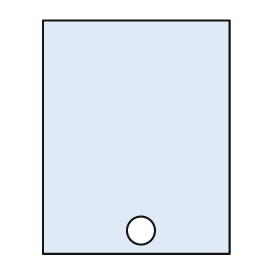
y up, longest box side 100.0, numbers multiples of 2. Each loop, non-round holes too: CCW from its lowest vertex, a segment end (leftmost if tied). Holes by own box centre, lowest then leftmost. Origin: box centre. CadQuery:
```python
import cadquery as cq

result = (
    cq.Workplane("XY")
    .moveTo(-40.0, -50.0)
    .lineTo(40.0, -50.0)
    .lineTo(40.0, 50.0)
    .lineTo(-40.0, 50.0)
    .close()
    .moveTo(2.0, -40.0)
    .circle(6.0)
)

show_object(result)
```